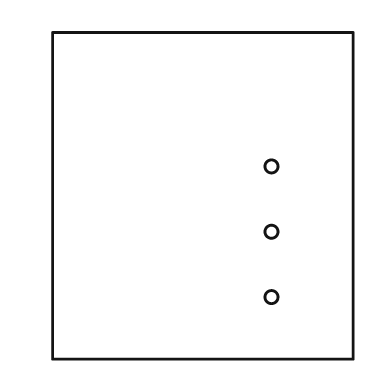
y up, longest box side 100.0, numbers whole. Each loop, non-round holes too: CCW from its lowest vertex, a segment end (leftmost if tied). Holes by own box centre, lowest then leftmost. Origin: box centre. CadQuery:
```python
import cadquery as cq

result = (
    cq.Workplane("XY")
    .moveTo(-46.0, -50.0)
    .lineTo(46.0, -50.0)
    .lineTo(46.0, 50.0)
    .lineTo(-46.0, 50.0)
    .close()
    .moveTo(21.0, -31.0)
    .circle(2.0)
    .moveTo(21.0, -11.0)
    .circle(2.0)
    .moveTo(21.0, 9.0)
    .circle(2.0)
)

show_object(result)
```